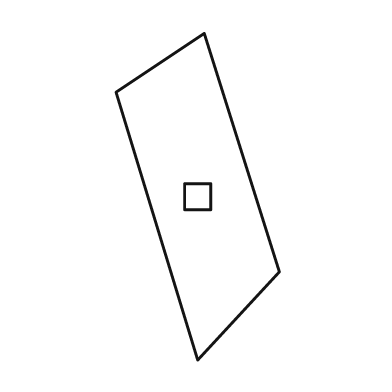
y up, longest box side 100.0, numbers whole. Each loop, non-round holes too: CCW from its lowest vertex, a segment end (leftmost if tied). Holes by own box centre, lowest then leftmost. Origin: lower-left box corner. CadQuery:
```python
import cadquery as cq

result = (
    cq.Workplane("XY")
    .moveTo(25.0, 0.0)
    .lineTo(50.0, 27.0)
    .lineTo(27.0, 100.0)
    .lineTo(0.0, 82.0)
    .close()
    .moveTo(21.0, 46.0)
    .lineTo(29.0, 46.0)
    .lineTo(29.0, 54.0)
    .lineTo(21.0, 54.0)
    .close()
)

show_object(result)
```